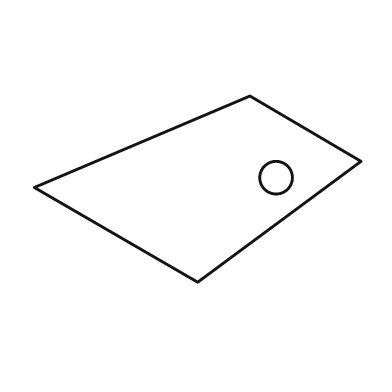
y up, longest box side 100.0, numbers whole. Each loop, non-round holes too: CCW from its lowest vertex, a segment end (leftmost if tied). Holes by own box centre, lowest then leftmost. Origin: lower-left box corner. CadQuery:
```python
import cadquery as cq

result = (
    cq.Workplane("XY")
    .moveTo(50.0, 0.0)
    .lineTo(100.0, 37.0)
    .lineTo(66.0, 57.0)
    .lineTo(0.0, 29.0)
    .close()
    .moveTo(74.0, 32.0)
    .circle(5.0)
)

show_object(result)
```